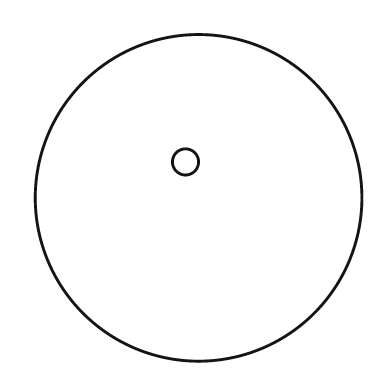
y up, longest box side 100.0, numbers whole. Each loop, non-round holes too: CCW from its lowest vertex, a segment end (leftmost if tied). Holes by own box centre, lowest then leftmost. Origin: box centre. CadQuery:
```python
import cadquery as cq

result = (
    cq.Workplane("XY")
    .moveTo(0.0, 0.0)
    .circle(50.0)
    .moveTo(-4.0, 11.0)
    .circle(4.0)
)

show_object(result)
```